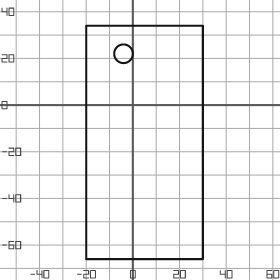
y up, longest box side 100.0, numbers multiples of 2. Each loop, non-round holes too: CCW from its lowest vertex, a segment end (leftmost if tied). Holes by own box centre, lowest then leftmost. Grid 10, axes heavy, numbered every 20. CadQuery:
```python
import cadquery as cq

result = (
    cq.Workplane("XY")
    .moveTo(-20.0, -66.0)
    .lineTo(30.0, -66.0)
    .lineTo(30.0, 34.0)
    .lineTo(-20.0, 34.0)
    .close()
    .moveTo(-4.0, 22.0)
    .circle(4.0)
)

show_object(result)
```